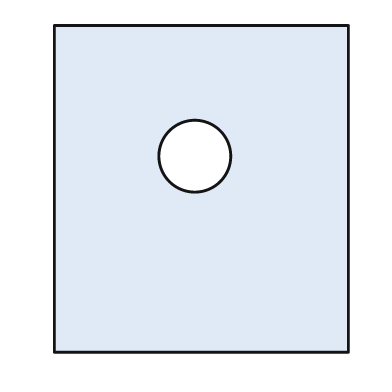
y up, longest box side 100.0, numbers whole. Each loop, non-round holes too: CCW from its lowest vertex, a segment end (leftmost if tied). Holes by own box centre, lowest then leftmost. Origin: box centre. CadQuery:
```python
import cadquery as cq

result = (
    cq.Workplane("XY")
    .moveTo(-45.0, -50.0)
    .lineTo(45.0, -50.0)
    .lineTo(45.0, 50.0)
    .lineTo(-45.0, 50.0)
    .close()
    .moveTo(-2.0, 10.0)
    .circle(11.0)
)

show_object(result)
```